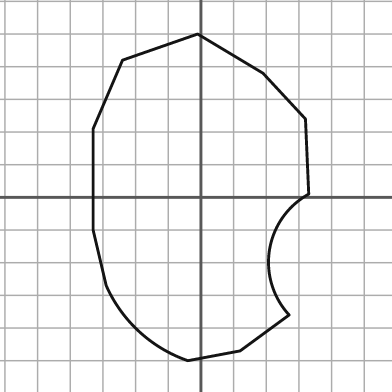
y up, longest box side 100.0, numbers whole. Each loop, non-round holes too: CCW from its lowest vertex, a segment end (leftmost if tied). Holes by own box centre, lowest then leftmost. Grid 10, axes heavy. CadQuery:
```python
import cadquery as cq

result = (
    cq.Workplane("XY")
    .moveTo(-4.0, -50.0)
    .lineTo(12.0, -47.0)
    .lineTo(27.0, -36.0)
    .threePointArc((21.0, -16.0), (33.0, 1.0))
    .lineTo(32.0, 24.0)
    .lineTo(19.0, 38.0)
    .lineTo(-1.0, 50.0)
    .lineTo(-24.0, 42.0)
    .lineTo(-33.0, 21.0)
    .lineTo(-33.0, -10.0)
    .lineTo(-29.0, -27.0)
    .threePointArc((-19.0, -41.0), (-4.0, -50.0))
    .close()
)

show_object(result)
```